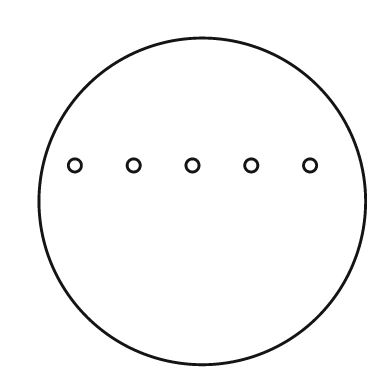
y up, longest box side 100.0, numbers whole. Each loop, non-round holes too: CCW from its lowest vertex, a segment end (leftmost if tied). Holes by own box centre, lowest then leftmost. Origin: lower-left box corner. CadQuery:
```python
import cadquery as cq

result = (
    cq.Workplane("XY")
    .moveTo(50.0, 50.0)
    .circle(50.0)
    .moveTo(11.0, 61.0)
    .circle(2.0)
    .moveTo(29.0, 61.0)
    .circle(2.0)
    .moveTo(47.0, 61.0)
    .circle(2.0)
    .moveTo(65.0, 61.0)
    .circle(2.0)
    .moveTo(83.0, 61.0)
    .circle(2.0)
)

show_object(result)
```